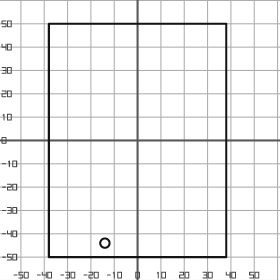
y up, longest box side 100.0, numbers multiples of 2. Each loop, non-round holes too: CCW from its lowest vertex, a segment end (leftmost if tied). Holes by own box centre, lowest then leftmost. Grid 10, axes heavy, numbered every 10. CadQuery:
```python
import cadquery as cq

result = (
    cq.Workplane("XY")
    .moveTo(-38.0, -50.0)
    .lineTo(38.0, -50.0)
    .lineTo(38.0, 50.0)
    .lineTo(-38.0, 50.0)
    .close()
    .moveTo(-14.0, -44.0)
    .circle(2.0)
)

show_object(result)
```